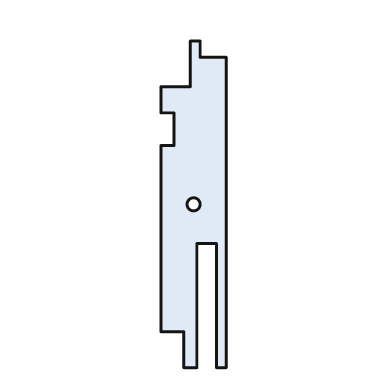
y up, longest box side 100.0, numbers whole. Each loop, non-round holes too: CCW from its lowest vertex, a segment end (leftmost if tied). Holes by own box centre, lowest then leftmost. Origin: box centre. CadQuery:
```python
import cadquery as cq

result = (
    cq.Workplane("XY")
    .moveTo(-3.0, -50.0)
    .lineTo(1.0, -50.0)
    .lineTo(1.0, -12.0)
    .lineTo(7.0, -12.0)
    .lineTo(7.0, -50.0)
    .lineTo(10.0, -50.0)
    .lineTo(10.0, 45.0)
    .lineTo(2.0, 45.0)
    .lineTo(2.0, 50.0)
    .lineTo(-1.0, 50.0)
    .lineTo(-1.0, 36.0)
    .lineTo(-10.0, 36.0)
    .lineTo(-10.0, 28.0)
    .lineTo(-6.0, 28.0)
    .lineTo(-6.0, 18.0)
    .lineTo(-10.0, 18.0)
    .lineTo(-10.0, -39.0)
    .lineTo(-3.0, -39.0)
    .close()
    .moveTo(0.0, 0.0)
    .circle(2.0)
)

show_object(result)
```